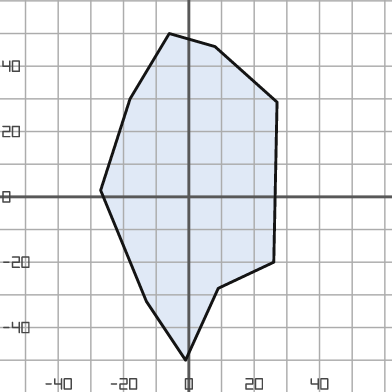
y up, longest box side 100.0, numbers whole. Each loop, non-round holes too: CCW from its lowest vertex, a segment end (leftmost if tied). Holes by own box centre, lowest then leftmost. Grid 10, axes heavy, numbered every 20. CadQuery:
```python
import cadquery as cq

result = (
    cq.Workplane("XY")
    .moveTo(-1.0, -50.0)
    .lineTo(9.0, -28.0)
    .lineTo(26.0, -20.0)
    .lineTo(27.0, 29.0)
    .lineTo(8.0, 46.0)
    .lineTo(-6.0, 50.0)
    .lineTo(-18.0, 30.0)
    .lineTo(-27.0, 2.0)
    .lineTo(-13.0, -32.0)
    .close()
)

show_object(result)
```